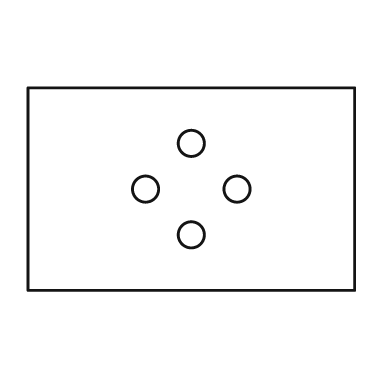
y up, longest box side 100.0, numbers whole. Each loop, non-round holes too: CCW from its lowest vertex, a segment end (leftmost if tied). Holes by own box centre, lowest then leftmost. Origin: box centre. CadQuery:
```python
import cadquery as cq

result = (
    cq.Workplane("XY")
    .moveTo(-50.0, -31.0)
    .lineTo(50.0, -31.0)
    .lineTo(50.0, 31.0)
    .lineTo(-50.0, 31.0)
    .close()
    .moveTo(0.0, -14.0)
    .circle(4.0)
    .moveTo(-14.0, 0.0)
    .circle(4.0)
    .moveTo(14.0, 0.0)
    .circle(4.0)
    .moveTo(0.0, 14.0)
    .circle(4.0)
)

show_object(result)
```